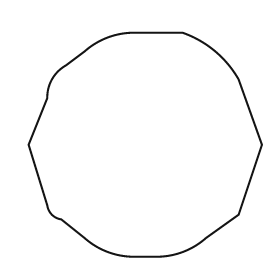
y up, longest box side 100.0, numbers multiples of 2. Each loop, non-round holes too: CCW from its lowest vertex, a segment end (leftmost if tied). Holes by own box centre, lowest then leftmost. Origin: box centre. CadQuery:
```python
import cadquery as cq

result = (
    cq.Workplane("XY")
    .moveTo(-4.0, -48.0)
    .lineTo(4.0, -48.0)
    .threePointArc((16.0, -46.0), (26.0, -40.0))
    .lineTo(40.0, -30.0)
    .lineTo(50.0, 0.0)
    .lineTo(40.0, 28.0)
    .threePointArc((30.0, 40.0), (16.0, 48.0))
    .lineTo(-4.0, 48.0)
    .threePointArc((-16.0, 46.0), (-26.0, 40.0))
    .lineTo(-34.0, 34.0)
    .threePointArc((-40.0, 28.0), (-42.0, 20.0))
    .lineTo(-50.0, 0.0)
    .lineTo(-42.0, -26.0)
    .threePointArc((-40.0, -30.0), (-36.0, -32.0))
    .lineTo(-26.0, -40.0)
    .threePointArc((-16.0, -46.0), (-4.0, -48.0))
    .close()
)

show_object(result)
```